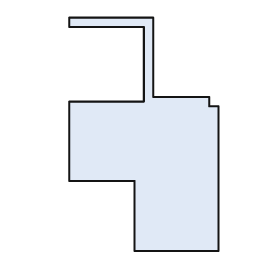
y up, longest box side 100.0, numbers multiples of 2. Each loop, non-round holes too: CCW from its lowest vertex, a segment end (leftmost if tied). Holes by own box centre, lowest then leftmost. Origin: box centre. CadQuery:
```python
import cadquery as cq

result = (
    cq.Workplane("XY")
    .moveTo(-4.0, -50.0)
    .lineTo(32.0, -50.0)
    .lineTo(32.0, 12.0)
    .lineTo(28.0, 12.0)
    .lineTo(28.0, 16.0)
    .lineTo(4.0, 16.0)
    .lineTo(4.0, 50.0)
    .lineTo(-32.0, 50.0)
    .lineTo(-32.0, 46.0)
    .lineTo(0.0, 46.0)
    .lineTo(0.0, 14.0)
    .lineTo(-32.0, 14.0)
    .lineTo(-32.0, -20.0)
    .lineTo(-4.0, -20.0)
    .close()
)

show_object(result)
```